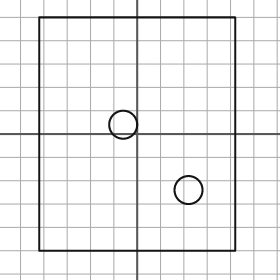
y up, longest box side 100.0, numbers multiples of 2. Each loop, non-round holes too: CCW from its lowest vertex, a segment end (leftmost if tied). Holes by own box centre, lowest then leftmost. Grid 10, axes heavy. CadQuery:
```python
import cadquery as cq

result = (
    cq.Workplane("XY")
    .moveTo(-42.0, -50.0)
    .lineTo(42.0, -50.0)
    .lineTo(42.0, 50.0)
    .lineTo(-42.0, 50.0)
    .close()
    .moveTo(22.0, -24.0)
    .circle(6.0)
    .moveTo(-6.0, 4.0)
    .circle(6.0)
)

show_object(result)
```